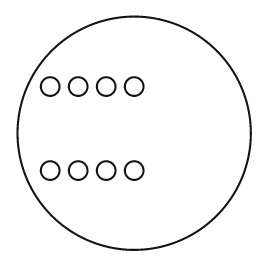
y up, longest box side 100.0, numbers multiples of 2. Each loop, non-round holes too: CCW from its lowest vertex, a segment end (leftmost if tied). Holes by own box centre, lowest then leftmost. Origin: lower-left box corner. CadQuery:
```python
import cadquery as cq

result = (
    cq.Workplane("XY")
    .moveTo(50.0, 50.0)
    .circle(50.0)
    .moveTo(14.0, 34.0)
    .circle(4.0)
    .moveTo(26.0, 34.0)
    .circle(4.0)
    .moveTo(38.0, 34.0)
    .circle(4.0)
    .moveTo(50.0, 34.0)
    .circle(4.0)
    .moveTo(14.0, 70.0)
    .circle(4.0)
    .moveTo(26.0, 70.0)
    .circle(4.0)
    .moveTo(38.0, 70.0)
    .circle(4.0)
    .moveTo(50.0, 70.0)
    .circle(4.0)
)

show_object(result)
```